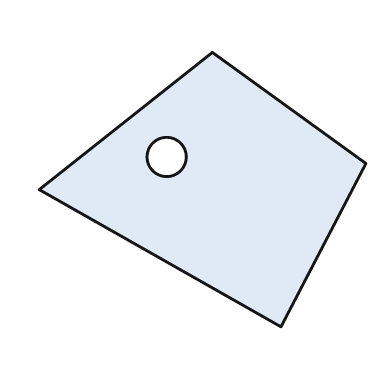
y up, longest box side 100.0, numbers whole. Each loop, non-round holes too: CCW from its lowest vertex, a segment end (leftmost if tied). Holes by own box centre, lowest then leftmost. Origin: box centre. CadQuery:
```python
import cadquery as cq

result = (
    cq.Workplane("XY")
    .moveTo(24.0, -42.0)
    .lineTo(50.0, 8.0)
    .lineTo(3.0, 42.0)
    .lineTo(-50.0, 0.0)
    .close()
    .moveTo(-11.0, 10.0)
    .circle(6.0)
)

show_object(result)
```